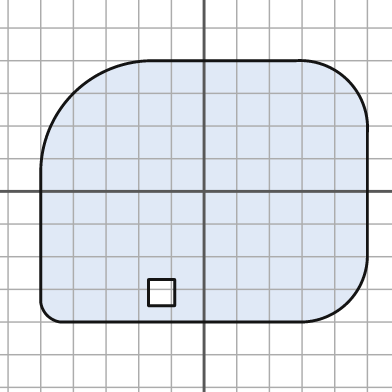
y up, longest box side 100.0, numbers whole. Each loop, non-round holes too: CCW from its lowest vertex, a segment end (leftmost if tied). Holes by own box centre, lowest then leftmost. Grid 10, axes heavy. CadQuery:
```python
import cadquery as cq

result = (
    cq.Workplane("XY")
    .moveTo(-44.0, -40.0)
    .lineTo(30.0, -40.0)
    .threePointArc((44.0, -34.0), (50.0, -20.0))
    .lineTo(50.0, 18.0)
    .threePointArc((44.0, 34.0), (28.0, 40.0))
    .lineTo(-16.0, 40.0)
    .threePointArc((-40.0, 30.0), (-50.0, 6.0))
    .lineTo(-50.0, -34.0)
    .threePointArc((-48.0, -38.0), (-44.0, -40.0))
    .close()
    .moveTo(-17.0, -35.0)
    .lineTo(-9.0, -35.0)
    .lineTo(-9.0, -27.0)
    .lineTo(-17.0, -27.0)
    .close()
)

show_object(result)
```